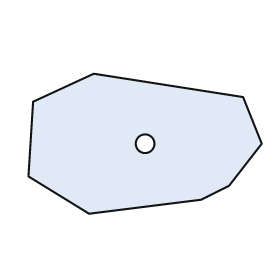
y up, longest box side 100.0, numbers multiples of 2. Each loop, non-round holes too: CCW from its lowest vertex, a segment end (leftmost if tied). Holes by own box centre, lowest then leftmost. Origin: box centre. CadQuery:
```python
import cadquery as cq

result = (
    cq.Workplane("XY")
    .moveTo(-24.0, -30.0)
    .lineTo(24.0, -24.0)
    .lineTo(36.0, -18.0)
    .lineTo(50.0, 0.0)
    .lineTo(42.0, 20.0)
    .lineTo(-22.0, 30.0)
    .lineTo(-48.0, 18.0)
    .lineTo(-50.0, -14.0)
    .close()
    .moveTo(0.0, 0.0)
    .circle(4.0)
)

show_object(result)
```